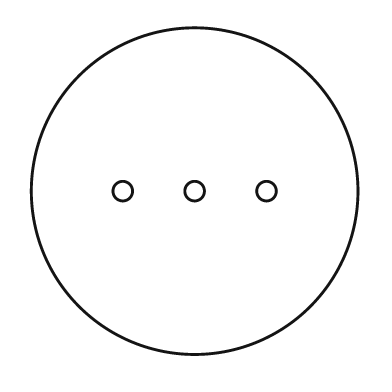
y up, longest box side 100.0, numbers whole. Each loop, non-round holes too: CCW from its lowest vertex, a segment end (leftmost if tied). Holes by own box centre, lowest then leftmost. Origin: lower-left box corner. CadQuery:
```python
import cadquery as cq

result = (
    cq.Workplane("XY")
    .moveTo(50.0, 50.0)
    .circle(50.0)
    .moveTo(28.0, 50.0)
    .circle(3.0)
    .moveTo(50.0, 50.0)
    .circle(3.0)
    .moveTo(72.0, 50.0)
    .circle(3.0)
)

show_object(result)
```